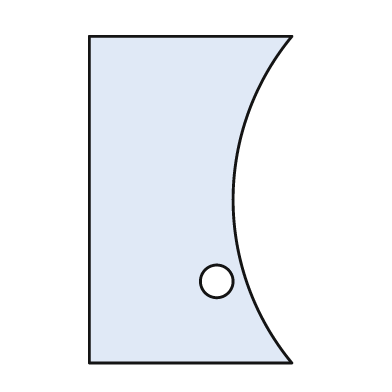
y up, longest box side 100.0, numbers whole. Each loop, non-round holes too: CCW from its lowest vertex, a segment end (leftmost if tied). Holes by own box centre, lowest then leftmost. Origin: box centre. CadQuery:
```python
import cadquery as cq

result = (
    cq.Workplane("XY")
    .moveTo(-31.0, -50.0)
    .lineTo(31.0, -50.0)
    .threePointArc((13.0, 0.0), (31.0, 50.0))
    .lineTo(-31.0, 50.0)
    .close()
    .moveTo(8.0, -25.0)
    .circle(5.0)
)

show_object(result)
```